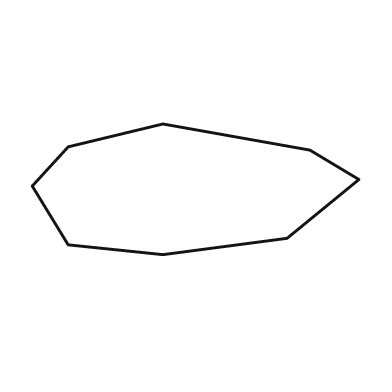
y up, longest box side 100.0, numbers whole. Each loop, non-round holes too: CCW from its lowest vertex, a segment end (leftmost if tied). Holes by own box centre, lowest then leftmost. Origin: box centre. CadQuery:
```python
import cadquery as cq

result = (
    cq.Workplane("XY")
    .moveTo(-10.0, -20.0)
    .lineTo(28.0, -15.0)
    .lineTo(50.0, 3.0)
    .lineTo(35.0, 12.0)
    .lineTo(-10.0, 20.0)
    .lineTo(-39.0, 13.0)
    .lineTo(-50.0, 1.0)
    .lineTo(-39.0, -17.0)
    .close()
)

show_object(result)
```